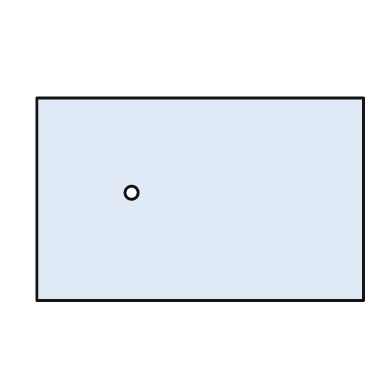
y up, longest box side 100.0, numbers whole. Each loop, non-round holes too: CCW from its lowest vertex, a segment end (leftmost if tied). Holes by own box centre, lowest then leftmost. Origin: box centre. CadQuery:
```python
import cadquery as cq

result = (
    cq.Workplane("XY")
    .moveTo(-50.0, -31.0)
    .lineTo(50.0, -31.0)
    .lineTo(50.0, 31.0)
    .lineTo(-50.0, 31.0)
    .close()
    .moveTo(-21.0, 2.0)
    .circle(2.0)
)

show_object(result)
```